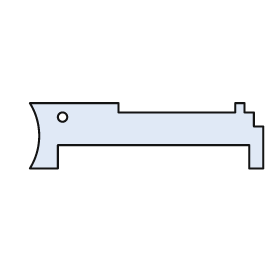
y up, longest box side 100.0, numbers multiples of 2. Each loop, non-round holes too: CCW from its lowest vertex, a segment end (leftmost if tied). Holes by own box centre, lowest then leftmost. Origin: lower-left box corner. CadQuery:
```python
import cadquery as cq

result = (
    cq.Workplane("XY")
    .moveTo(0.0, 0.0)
    .lineTo(12.0, 0.0)
    .lineTo(12.0, 10.0)
    .lineTo(94.0, 10.0)
    .lineTo(94.0, 0.0)
    .lineTo(100.0, 0.0)
    .lineTo(100.0, 18.0)
    .lineTo(96.0, 18.0)
    .lineTo(96.0, 24.0)
    .lineTo(92.0, 24.0)
    .lineTo(92.0, 28.0)
    .lineTo(88.0, 28.0)
    .lineTo(88.0, 24.0)
    .lineTo(38.0, 24.0)
    .lineTo(38.0, 28.0)
    .lineTo(0.0, 28.0)
    .threePointArc((4.0, 14.0), (0.0, 0.0))
    .close()
    .moveTo(14.0, 22.0)
    .circle(2.0)
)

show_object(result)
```